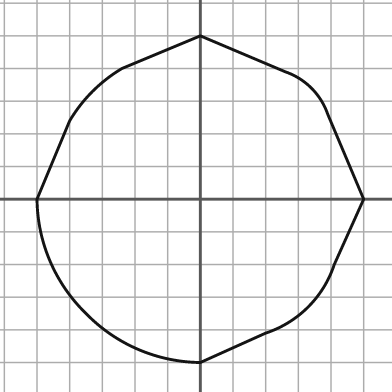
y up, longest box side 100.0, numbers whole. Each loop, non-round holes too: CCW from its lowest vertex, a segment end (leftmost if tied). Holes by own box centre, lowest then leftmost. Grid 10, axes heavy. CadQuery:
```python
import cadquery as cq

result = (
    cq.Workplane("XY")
    .moveTo(0.0, -50.0)
    .lineTo(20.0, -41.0)
    .threePointArc((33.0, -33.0), (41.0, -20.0))
    .lineTo(50.0, 0.0)
    .lineTo(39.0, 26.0)
    .threePointArc((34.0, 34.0), (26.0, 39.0))
    .lineTo(0.0, 50.0)
    .lineTo(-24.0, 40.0)
    .threePointArc((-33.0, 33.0), (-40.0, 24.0))
    .lineTo(-50.0, 0.0)
    .threePointArc((-46.0, -19.0), (-35.0, -35.0))
    .threePointArc((-19.0, -46.0), (0.0, -50.0))
    .close()
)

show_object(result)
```